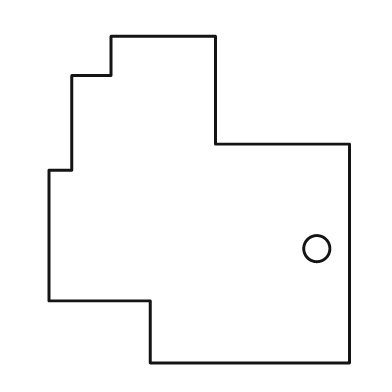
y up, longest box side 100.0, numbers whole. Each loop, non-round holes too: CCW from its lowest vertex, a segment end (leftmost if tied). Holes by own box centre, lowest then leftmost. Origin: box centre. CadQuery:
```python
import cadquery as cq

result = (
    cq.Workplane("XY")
    .moveTo(-15.0, -50.0)
    .lineTo(46.0, -50.0)
    .lineTo(46.0, 17.0)
    .lineTo(5.0, 17.0)
    .lineTo(5.0, 50.0)
    .lineTo(-27.0, 50.0)
    .lineTo(-27.0, 38.0)
    .lineTo(-39.0, 38.0)
    .lineTo(-39.0, 9.0)
    .lineTo(-46.0, 9.0)
    .lineTo(-46.0, -31.0)
    .lineTo(-15.0, -31.0)
    .close()
    .moveTo(36.0, -15.0)
    .circle(4.0)
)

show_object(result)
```